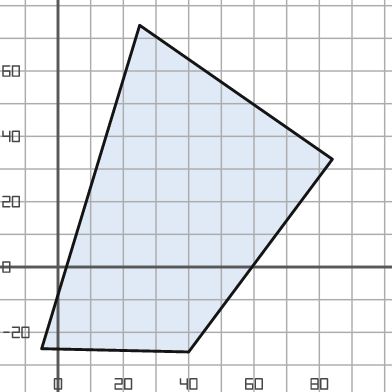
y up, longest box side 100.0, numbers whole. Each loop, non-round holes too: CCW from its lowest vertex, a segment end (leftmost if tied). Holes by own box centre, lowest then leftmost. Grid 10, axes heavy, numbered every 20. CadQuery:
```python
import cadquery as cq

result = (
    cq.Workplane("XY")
    .moveTo(40.0, -26.0)
    .lineTo(84.0, 33.0)
    .lineTo(25.0, 74.0)
    .lineTo(-5.0, -25.0)
    .close()
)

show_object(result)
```